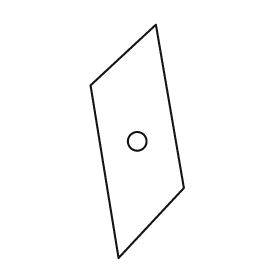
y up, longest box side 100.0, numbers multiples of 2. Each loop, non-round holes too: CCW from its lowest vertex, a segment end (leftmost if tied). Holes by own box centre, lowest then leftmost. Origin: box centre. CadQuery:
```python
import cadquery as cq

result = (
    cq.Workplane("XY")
    .moveTo(-8.0, -50.0)
    .lineTo(20.0, -20.0)
    .lineTo(8.0, 50.0)
    .lineTo(-20.0, 24.0)
    .close()
    .moveTo(0.0, 0.0)
    .circle(4.0)
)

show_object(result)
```